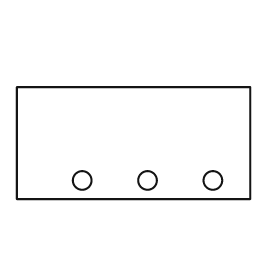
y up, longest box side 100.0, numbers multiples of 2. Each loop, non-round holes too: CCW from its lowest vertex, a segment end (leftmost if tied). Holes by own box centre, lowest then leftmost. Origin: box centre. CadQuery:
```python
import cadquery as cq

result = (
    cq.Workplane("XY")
    .moveTo(-50.0, -24.0)
    .lineTo(50.0, -24.0)
    .lineTo(50.0, 24.0)
    .lineTo(-50.0, 24.0)
    .close()
    .moveTo(-22.0, -16.0)
    .circle(4.0)
    .moveTo(6.0, -16.0)
    .circle(4.0)
    .moveTo(34.0, -16.0)
    .circle(4.0)
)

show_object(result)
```